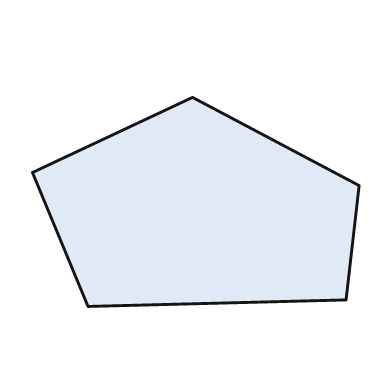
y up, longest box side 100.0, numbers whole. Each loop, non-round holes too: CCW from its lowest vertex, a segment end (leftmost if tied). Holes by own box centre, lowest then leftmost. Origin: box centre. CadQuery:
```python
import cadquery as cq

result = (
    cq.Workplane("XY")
    .moveTo(-33.0, -32.0)
    .lineTo(46.0, -30.0)
    .lineTo(50.0, 5.0)
    .lineTo(-1.0, 32.0)
    .lineTo(-50.0, 9.0)
    .close()
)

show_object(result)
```